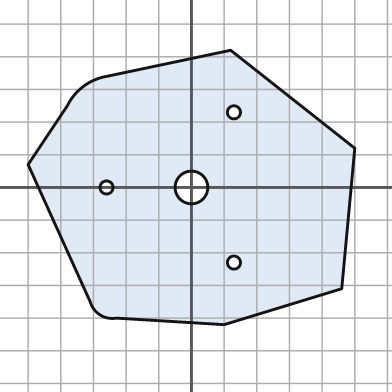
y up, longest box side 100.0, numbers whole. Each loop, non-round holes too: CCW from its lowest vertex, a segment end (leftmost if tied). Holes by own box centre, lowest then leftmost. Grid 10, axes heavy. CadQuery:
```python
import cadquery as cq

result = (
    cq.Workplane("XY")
    .moveTo(10.0, -42.0)
    .lineTo(46.0, -31.0)
    .lineTo(50.0, 12.0)
    .lineTo(12.0, 42.0)
    .lineTo(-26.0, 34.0)
    .threePointArc((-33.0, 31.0), (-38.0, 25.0))
    .lineTo(-50.0, 7.0)
    .lineTo(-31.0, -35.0)
    .threePointArc((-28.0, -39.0), (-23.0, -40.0))
    .close()
    .moveTo(13.0, -23.0)
    .circle(2.0)
    .moveTo(-26.0, 0.0)
    .circle(2.0)
    .moveTo(0.0, 0.0)
    .circle(5.0)
    .moveTo(13.0, 23.0)
    .circle(2.0)
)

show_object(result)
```